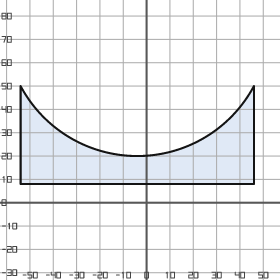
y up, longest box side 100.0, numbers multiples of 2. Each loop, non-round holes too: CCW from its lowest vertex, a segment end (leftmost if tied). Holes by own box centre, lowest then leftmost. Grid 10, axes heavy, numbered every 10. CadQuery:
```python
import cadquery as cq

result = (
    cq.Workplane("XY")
    .moveTo(-54.0, 8.0)
    .lineTo(46.0, 8.0)
    .lineTo(46.0, 50.0)
    .threePointArc((-4.0, 20.0), (-54.0, 50.0))
    .close()
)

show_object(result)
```